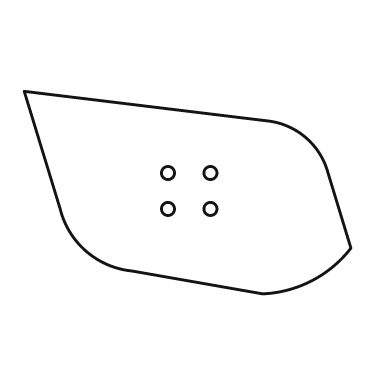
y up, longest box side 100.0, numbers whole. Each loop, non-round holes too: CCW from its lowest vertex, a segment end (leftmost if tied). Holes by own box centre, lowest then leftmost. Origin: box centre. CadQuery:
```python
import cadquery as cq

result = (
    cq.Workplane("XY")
    .moveTo(23.0, -31.0)
    .threePointArc((38.0, -27.0), (50.0, -17.0))
    .lineTo(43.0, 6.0)
    .threePointArc((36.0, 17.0), (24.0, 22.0))
    .lineTo(-50.0, 31.0)
    .lineTo(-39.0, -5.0)
    .threePointArc((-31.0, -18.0), (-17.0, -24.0))
    .close()
    .moveTo(-6.0, -5.0)
    .circle(2.0)
    .moveTo(7.0, -5.0)
    .circle(2.0)
    .moveTo(-6.0, 6.0)
    .circle(2.0)
    .moveTo(7.0, 6.0)
    .circle(2.0)
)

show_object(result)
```